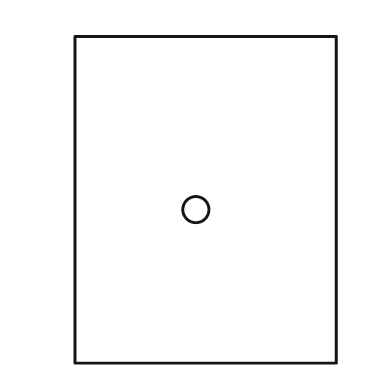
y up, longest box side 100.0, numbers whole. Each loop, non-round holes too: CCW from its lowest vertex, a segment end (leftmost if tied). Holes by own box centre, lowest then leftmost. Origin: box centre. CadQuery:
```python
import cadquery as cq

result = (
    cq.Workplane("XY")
    .moveTo(-40.0, -50.0)
    .lineTo(40.0, -50.0)
    .lineTo(40.0, 50.0)
    .lineTo(-40.0, 50.0)
    .close()
    .moveTo(-3.0, -3.0)
    .circle(4.0)
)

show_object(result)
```